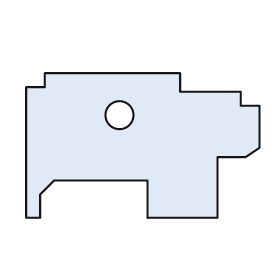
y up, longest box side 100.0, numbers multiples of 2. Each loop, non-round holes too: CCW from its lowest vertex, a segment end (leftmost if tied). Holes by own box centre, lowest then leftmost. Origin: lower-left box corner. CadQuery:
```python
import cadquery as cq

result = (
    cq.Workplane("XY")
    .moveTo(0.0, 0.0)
    .lineTo(6.0, 0.0)
    .lineTo(6.0, 10.0)
    .lineTo(12.0, 16.0)
    .lineTo(52.0, 16.0)
    .lineTo(52.0, 0.0)
    .lineTo(82.0, 0.0)
    .lineTo(82.0, 26.0)
    .lineTo(94.0, 26.0)
    .lineTo(100.0, 30.0)
    .lineTo(100.0, 48.0)
    .lineTo(92.0, 48.0)
    .lineTo(92.0, 54.0)
    .lineTo(66.0, 54.0)
    .lineTo(66.0, 62.0)
    .lineTo(8.0, 62.0)
    .lineTo(8.0, 56.0)
    .lineTo(0.0, 56.0)
    .close()
    .moveTo(40.0, 44.0)
    .circle(6.0)
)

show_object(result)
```